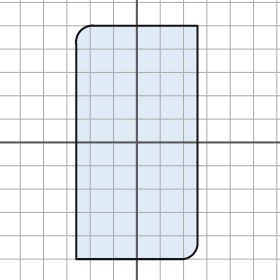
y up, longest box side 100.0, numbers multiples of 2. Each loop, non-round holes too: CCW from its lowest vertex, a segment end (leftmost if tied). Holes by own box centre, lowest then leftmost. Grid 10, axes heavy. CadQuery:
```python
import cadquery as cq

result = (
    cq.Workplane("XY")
    .moveTo(-26.0, -50.0)
    .lineTo(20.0, -50.0)
    .threePointArc((24.0, -48.0), (26.0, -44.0))
    .lineTo(26.0, 50.0)
    .lineTo(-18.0, 50.0)
    .threePointArc((-24.0, 48.0), (-26.0, 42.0))
    .close()
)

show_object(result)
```